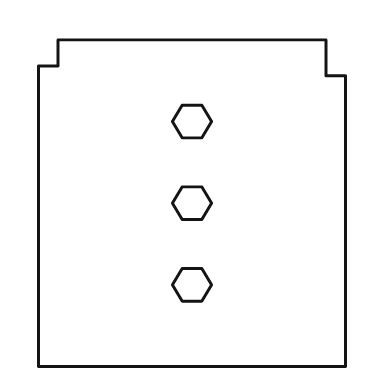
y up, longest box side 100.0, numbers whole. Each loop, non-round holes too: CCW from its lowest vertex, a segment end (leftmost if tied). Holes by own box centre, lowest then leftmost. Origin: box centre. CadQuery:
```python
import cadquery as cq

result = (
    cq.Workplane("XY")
    .moveTo(-47.0, -50.0)
    .lineTo(47.0, -50.0)
    .lineTo(47.0, 39.0)
    .lineTo(41.0, 39.0)
    .lineTo(41.0, 50.0)
    .lineTo(-41.0, 50.0)
    .lineTo(-41.0, 42.0)
    .lineTo(-47.0, 42.0)
    .close()
    .moveTo(-3.0, -30.0)
    .lineTo(3.0, -30.0)
    .lineTo(6.0, -25.0)
    .lineTo(3.0, -20.0)
    .lineTo(-3.0, -20.0)
    .lineTo(-6.0, -25.0)
    .close()
    .moveTo(-3.0, -5.0)
    .lineTo(3.0, -5.0)
    .lineTo(6.0, 0.0)
    .lineTo(3.0, 5.0)
    .lineTo(-3.0, 5.0)
    .lineTo(-6.0, 0.0)
    .close()
    .moveTo(-3.0, 20.0)
    .lineTo(3.0, 20.0)
    .lineTo(6.0, 25.0)
    .lineTo(3.0, 30.0)
    .lineTo(-3.0, 30.0)
    .lineTo(-6.0, 25.0)
    .close()
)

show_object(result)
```